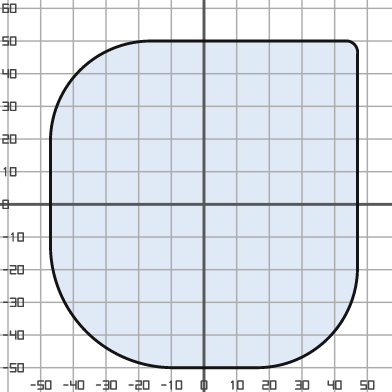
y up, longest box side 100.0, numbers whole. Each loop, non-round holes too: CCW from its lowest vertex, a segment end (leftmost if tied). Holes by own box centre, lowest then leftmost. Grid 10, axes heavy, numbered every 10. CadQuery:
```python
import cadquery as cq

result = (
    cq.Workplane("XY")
    .moveTo(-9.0, -50.0)
    .lineTo(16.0, -50.0)
    .threePointArc((38.0, -41.0), (47.0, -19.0))
    .lineTo(47.0, 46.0)
    .threePointArc((46.0, 49.0), (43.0, 50.0))
    .lineTo(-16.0, 50.0)
    .threePointArc((-38.0, 41.0), (-47.0, 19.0))
    .lineTo(-47.0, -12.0)
    .threePointArc((-36.0, -39.0), (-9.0, -50.0))
    .close()
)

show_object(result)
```